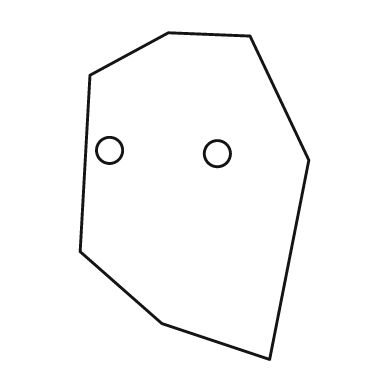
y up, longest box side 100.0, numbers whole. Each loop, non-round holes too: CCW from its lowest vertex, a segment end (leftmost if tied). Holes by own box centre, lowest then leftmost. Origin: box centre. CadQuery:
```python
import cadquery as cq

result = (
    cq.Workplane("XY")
    .moveTo(23.0, -50.0)
    .lineTo(35.0, 11.0)
    .lineTo(17.0, 49.0)
    .lineTo(-8.0, 50.0)
    .lineTo(-32.0, 37.0)
    .lineTo(-35.0, -17.0)
    .lineTo(-10.0, -39.0)
    .close()
    .moveTo(7.0, 13.0)
    .circle(4.0)
    .moveTo(-26.0, 14.0)
    .circle(4.0)
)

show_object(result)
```